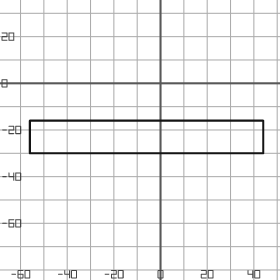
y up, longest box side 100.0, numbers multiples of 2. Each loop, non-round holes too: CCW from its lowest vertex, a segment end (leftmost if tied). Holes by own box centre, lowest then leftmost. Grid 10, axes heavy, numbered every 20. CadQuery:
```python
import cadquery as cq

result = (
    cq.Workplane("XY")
    .moveTo(-56.0, -30.0)
    .lineTo(44.0, -30.0)
    .lineTo(44.0, -16.0)
    .lineTo(-56.0, -16.0)
    .close()
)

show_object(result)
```